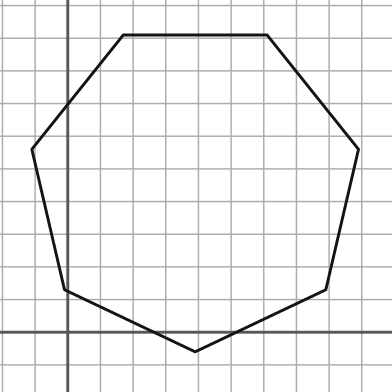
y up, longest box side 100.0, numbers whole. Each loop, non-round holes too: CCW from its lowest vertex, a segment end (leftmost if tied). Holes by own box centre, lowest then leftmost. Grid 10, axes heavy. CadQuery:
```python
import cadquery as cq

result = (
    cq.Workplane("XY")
    .moveTo(39.0, -6.0)
    .lineTo(79.0, 13.0)
    .lineTo(89.0, 56.0)
    .lineTo(61.0, 91.0)
    .lineTo(17.0, 91.0)
    .lineTo(-11.0, 56.0)
    .lineTo(-1.0, 13.0)
    .close()
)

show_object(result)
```